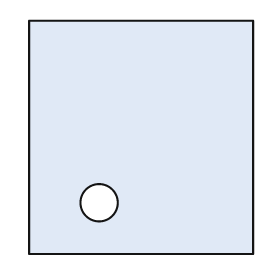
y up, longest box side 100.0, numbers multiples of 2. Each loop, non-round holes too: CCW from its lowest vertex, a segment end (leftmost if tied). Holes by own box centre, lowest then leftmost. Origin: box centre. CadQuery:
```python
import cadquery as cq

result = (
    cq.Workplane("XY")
    .moveTo(-48.0, -50.0)
    .lineTo(48.0, -50.0)
    .lineTo(48.0, 50.0)
    .lineTo(-48.0, 50.0)
    .close()
    .moveTo(-18.0, -28.0)
    .circle(8.0)
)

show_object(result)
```